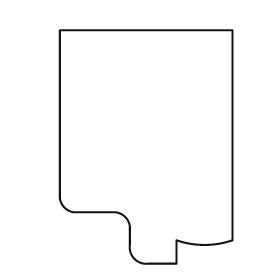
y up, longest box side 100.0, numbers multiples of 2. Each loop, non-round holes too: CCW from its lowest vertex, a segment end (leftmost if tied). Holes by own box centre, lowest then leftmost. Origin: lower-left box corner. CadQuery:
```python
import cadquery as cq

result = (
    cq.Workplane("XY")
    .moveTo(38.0, 0.0)
    .lineTo(50.0, 0.0)
    .lineTo(50.0, 10.0)
    .threePointArc((62.0, 8.0), (74.0, 10.0))
    .lineTo(74.0, 100.0)
    .lineTo(0.0, 100.0)
    .lineTo(0.0, 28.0)
    .threePointArc((2.0, 24.0), (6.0, 22.0))
    .lineTo(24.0, 22.0)
    .threePointArc((28.0, 20.0), (30.0, 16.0))
    .lineTo(30.0, 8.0)
    .threePointArc((32.0, 2.0), (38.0, 0.0))
    .close()
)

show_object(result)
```